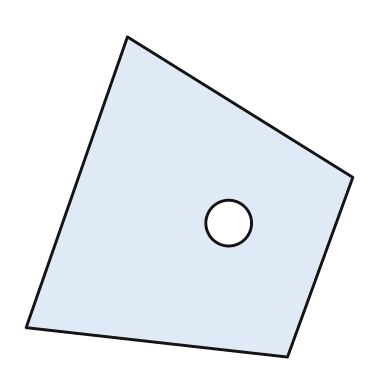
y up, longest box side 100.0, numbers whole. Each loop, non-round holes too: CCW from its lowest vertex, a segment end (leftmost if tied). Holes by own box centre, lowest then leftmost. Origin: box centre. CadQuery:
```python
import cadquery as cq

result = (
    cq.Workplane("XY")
    .moveTo(30.0, -49.0)
    .lineTo(50.0, 6.0)
    .lineTo(-19.0, 49.0)
    .lineTo(-50.0, -40.0)
    .close()
    .moveTo(12.0, -8.0)
    .circle(7.0)
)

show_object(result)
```